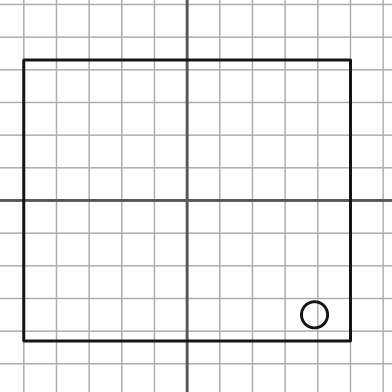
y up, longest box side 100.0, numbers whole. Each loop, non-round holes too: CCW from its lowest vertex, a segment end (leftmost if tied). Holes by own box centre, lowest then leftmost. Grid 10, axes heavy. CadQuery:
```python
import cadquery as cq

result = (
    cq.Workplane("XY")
    .moveTo(-50.0, -43.0)
    .lineTo(50.0, -43.0)
    .lineTo(50.0, 43.0)
    .lineTo(-50.0, 43.0)
    .close()
    .moveTo(39.0, -35.0)
    .circle(4.0)
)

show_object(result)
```